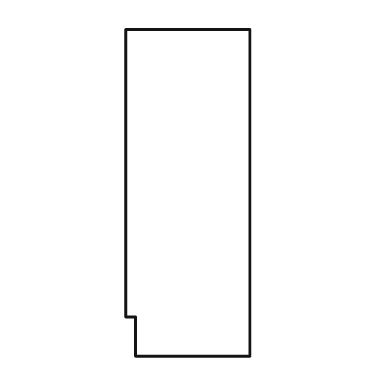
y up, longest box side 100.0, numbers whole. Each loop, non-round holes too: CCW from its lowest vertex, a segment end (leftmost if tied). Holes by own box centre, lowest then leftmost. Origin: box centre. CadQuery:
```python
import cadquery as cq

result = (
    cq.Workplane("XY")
    .moveTo(-16.0, -50.0)
    .lineTo(19.0, -50.0)
    .lineTo(19.0, 50.0)
    .lineTo(-19.0, 50.0)
    .lineTo(-19.0, -38.0)
    .lineTo(-16.0, -38.0)
    .close()
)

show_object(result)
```